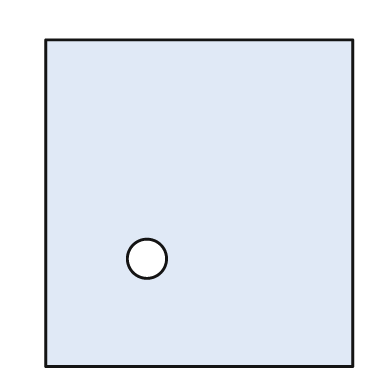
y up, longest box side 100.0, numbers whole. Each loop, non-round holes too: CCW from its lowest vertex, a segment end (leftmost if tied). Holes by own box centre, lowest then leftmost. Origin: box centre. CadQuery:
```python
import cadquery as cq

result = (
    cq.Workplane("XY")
    .moveTo(-47.0, -50.0)
    .lineTo(47.0, -50.0)
    .lineTo(47.0, 50.0)
    .lineTo(-47.0, 50.0)
    .close()
    .moveTo(-16.0, -17.0)
    .circle(6.0)
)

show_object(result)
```